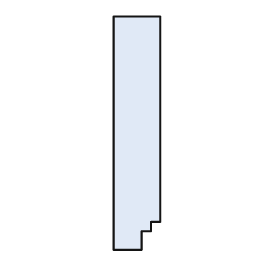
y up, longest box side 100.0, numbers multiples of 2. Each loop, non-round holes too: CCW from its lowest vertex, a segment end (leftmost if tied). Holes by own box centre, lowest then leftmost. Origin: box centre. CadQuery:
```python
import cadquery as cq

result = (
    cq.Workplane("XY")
    .moveTo(-10.0, -50.0)
    .lineTo(2.0, -50.0)
    .lineTo(2.0, -42.0)
    .lineTo(6.0, -42.0)
    .lineTo(6.0, -38.0)
    .lineTo(10.0, -38.0)
    .lineTo(10.0, 50.0)
    .lineTo(-10.0, 50.0)
    .close()
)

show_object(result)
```